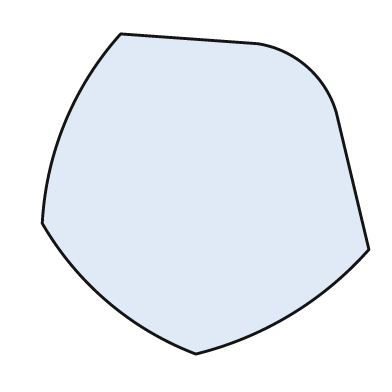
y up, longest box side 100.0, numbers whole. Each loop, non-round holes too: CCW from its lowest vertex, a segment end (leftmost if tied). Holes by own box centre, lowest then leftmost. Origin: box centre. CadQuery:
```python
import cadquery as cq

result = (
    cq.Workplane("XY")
    .moveTo(-3.0, -49.0)
    .threePointArc((26.0, -37.0), (50.0, -17.0))
    .lineTo(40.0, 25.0)
    .threePointArc((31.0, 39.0), (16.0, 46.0))
    .lineTo(-26.0, 49.0)
    .threePointArc((-43.0, 22.0), (-50.0, -9.0))
    .threePointArc((-30.0, -33.0), (-3.0, -49.0))
    .close()
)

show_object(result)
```